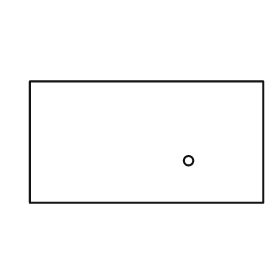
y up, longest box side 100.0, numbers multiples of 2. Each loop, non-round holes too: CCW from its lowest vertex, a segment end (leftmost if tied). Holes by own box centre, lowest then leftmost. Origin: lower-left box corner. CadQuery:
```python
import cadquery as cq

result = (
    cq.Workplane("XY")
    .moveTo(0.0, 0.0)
    .lineTo(100.0, 0.0)
    .lineTo(100.0, 52.0)
    .lineTo(0.0, 52.0)
    .close()
    .moveTo(68.0, 18.0)
    .circle(2.0)
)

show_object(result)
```